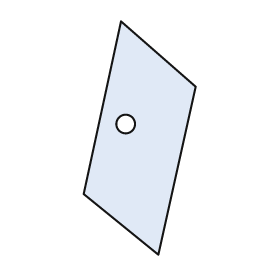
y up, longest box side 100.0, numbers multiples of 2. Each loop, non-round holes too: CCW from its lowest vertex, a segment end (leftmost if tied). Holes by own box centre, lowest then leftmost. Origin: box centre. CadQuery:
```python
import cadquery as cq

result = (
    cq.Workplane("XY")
    .moveTo(8.0, -50.0)
    .lineTo(24.0, 22.0)
    .lineTo(-8.0, 50.0)
    .lineTo(-24.0, -24.0)
    .close()
    .moveTo(-6.0, 6.0)
    .circle(4.0)
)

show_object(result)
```